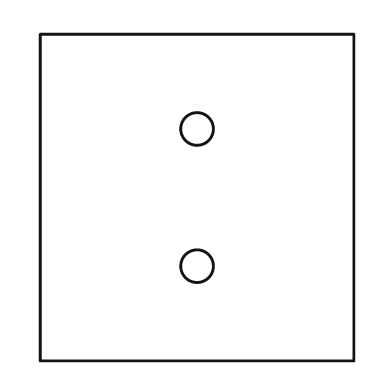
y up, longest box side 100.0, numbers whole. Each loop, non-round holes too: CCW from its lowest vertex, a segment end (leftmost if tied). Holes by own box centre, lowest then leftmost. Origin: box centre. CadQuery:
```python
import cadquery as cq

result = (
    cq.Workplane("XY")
    .moveTo(-48.0, -50.0)
    .lineTo(48.0, -50.0)
    .lineTo(48.0, 50.0)
    .lineTo(-48.0, 50.0)
    .close()
    .moveTo(0.0, -21.0)
    .circle(5.0)
    .moveTo(0.0, 21.0)
    .circle(5.0)
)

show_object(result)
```